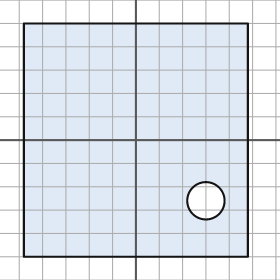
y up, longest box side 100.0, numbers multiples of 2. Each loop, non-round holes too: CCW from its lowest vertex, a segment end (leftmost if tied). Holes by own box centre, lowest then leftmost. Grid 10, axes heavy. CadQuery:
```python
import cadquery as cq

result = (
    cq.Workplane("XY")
    .moveTo(-48.0, -50.0)
    .lineTo(48.0, -50.0)
    .lineTo(48.0, 50.0)
    .lineTo(-48.0, 50.0)
    .close()
    .moveTo(30.0, -26.0)
    .circle(8.0)
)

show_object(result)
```